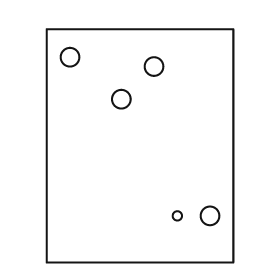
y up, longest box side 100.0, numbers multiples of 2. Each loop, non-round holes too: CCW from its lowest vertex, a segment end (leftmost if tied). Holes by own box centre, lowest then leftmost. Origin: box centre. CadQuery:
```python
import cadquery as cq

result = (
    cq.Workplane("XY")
    .moveTo(-40.0, -50.0)
    .lineTo(40.0, -50.0)
    .lineTo(40.0, 50.0)
    .lineTo(-40.0, 50.0)
    .close()
    .moveTo(16.0, -30.0)
    .circle(2.0)
    .moveTo(30.0, -30.0)
    .circle(4.0)
    .moveTo(-8.0, 20.0)
    .circle(4.0)
    .moveTo(6.0, 34.0)
    .circle(4.0)
    .moveTo(-30.0, 38.0)
    .circle(4.0)
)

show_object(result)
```